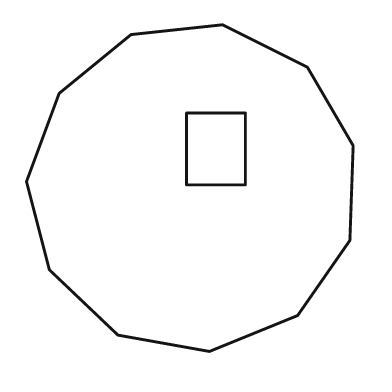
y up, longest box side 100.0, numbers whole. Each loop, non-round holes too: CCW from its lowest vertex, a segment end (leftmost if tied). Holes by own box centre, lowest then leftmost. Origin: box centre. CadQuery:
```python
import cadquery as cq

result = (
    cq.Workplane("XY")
    .moveTo(6.0, -50.0)
    .lineTo(33.0, -39.0)
    .lineTo(49.0, -16.0)
    .lineTo(50.0, 13.0)
    .lineTo(36.0, 37.0)
    .lineTo(10.0, 50.0)
    .lineTo(-18.0, 47.0)
    .lineTo(-40.0, 29.0)
    .lineTo(-50.0, 2.0)
    .lineTo(-43.0, -25.0)
    .lineTo(-22.0, -45.0)
    .close()
    .moveTo(-1.0, 1.0)
    .lineTo(17.0, 1.0)
    .lineTo(17.0, 23.0)
    .lineTo(-1.0, 23.0)
    .close()
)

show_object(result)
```